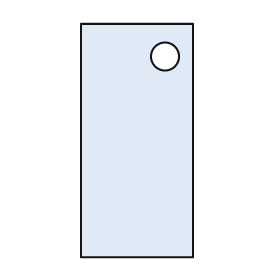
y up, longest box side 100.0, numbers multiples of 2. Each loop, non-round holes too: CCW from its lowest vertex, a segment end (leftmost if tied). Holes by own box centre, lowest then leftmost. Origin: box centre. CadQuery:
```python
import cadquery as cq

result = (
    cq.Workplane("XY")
    .moveTo(-24.0, -50.0)
    .lineTo(24.0, -50.0)
    .lineTo(24.0, 50.0)
    .lineTo(-24.0, 50.0)
    .close()
    .moveTo(12.0, 36.0)
    .circle(6.0)
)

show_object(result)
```